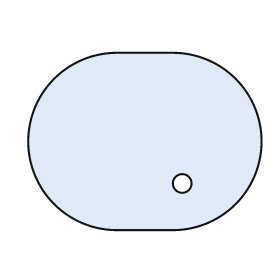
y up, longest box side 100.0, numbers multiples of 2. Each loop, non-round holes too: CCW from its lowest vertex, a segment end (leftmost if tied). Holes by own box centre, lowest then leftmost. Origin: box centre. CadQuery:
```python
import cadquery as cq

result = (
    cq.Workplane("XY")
    .moveTo(-12.0, -38.0)
    .lineTo(12.0, -38.0)
    .threePointArc((50.0, 0.0), (12.0, 38.0))
    .lineTo(-12.0, 38.0)
    .threePointArc((-50.0, 0.0), (-12.0, -38.0))
    .close()
    .moveTo(16.0, -18.0)
    .circle(4.0)
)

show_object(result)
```